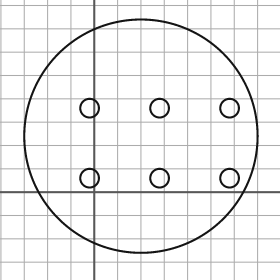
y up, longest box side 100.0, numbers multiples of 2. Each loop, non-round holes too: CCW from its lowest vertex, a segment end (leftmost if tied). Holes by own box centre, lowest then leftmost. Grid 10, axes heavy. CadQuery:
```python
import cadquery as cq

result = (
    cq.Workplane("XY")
    .moveTo(20.0, 24.0)
    .circle(50.0)
    .moveTo(-2.0, 6.0)
    .circle(4.0)
    .moveTo(28.0, 6.0)
    .circle(4.0)
    .moveTo(58.0, 6.0)
    .circle(4.0)
    .moveTo(-2.0, 36.0)
    .circle(4.0)
    .moveTo(28.0, 36.0)
    .circle(4.0)
    .moveTo(58.0, 36.0)
    .circle(4.0)
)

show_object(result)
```